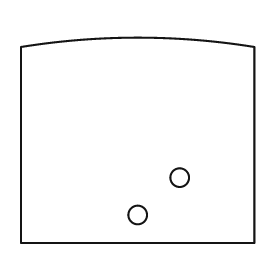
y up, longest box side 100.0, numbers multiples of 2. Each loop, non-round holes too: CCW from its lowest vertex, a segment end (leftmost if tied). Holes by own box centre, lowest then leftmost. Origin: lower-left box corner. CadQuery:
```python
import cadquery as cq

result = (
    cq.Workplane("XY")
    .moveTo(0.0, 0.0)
    .lineTo(100.0, 0.0)
    .lineTo(100.0, 84.0)
    .threePointArc((50.0, 88.0), (0.0, 84.0))
    .close()
    .moveTo(50.0, 12.0)
    .circle(4.0)
    .moveTo(68.0, 28.0)
    .circle(4.0)
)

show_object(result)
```